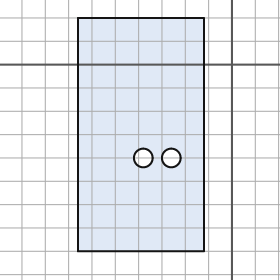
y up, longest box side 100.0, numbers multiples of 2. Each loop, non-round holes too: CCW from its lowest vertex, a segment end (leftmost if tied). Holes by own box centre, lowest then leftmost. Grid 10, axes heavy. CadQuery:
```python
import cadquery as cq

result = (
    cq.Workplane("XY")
    .moveTo(-66.0, -80.0)
    .lineTo(-12.0, -80.0)
    .lineTo(-12.0, 20.0)
    .lineTo(-66.0, 20.0)
    .close()
    .moveTo(-38.0, -40.0)
    .circle(4.0)
    .moveTo(-26.0, -40.0)
    .circle(4.0)
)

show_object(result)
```